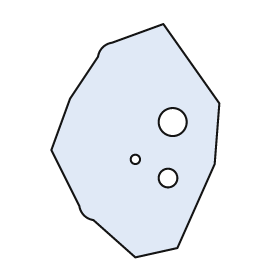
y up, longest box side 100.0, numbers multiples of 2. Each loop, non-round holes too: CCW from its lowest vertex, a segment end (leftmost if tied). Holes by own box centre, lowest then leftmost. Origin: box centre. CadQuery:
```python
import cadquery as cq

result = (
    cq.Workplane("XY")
    .moveTo(0.0, -50.0)
    .lineTo(18.0, -46.0)
    .lineTo(34.0, -10.0)
    .lineTo(36.0, 16.0)
    .lineTo(12.0, 50.0)
    .lineTo(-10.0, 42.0)
    .threePointArc((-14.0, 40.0), (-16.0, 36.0))
    .lineTo(-28.0, 18.0)
    .lineTo(-36.0, -4.0)
    .lineTo(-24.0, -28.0)
    .threePointArc((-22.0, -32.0), (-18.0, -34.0))
    .close()
    .moveTo(14.0, -16.0)
    .circle(4.0)
    .moveTo(0.0, -8.0)
    .circle(2.0)
    .moveTo(16.0, 8.0)
    .circle(6.0)
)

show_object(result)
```